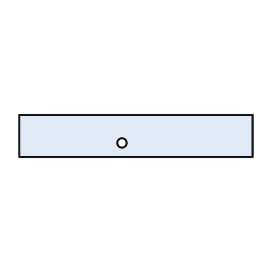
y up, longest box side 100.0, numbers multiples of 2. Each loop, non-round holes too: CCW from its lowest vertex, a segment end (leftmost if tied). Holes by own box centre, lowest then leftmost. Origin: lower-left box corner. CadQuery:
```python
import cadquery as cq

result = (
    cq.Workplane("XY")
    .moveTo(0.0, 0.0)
    .lineTo(100.0, 0.0)
    .lineTo(100.0, 18.0)
    .lineTo(0.0, 18.0)
    .close()
    .moveTo(44.0, 6.0)
    .circle(2.0)
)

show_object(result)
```